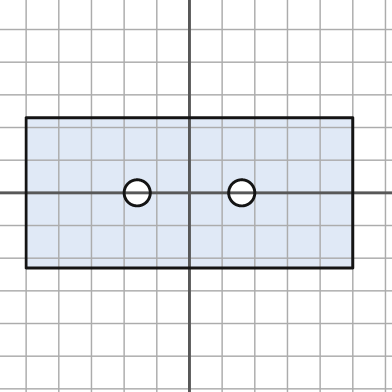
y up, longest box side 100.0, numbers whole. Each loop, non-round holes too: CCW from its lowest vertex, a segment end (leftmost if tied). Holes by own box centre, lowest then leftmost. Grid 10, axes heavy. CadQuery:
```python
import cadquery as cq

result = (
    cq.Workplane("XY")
    .moveTo(-50.0, -23.0)
    .lineTo(50.0, -23.0)
    .lineTo(50.0, 23.0)
    .lineTo(-50.0, 23.0)
    .close()
    .moveTo(-16.0, 0.0)
    .circle(4.0)
    .moveTo(16.0, 0.0)
    .circle(4.0)
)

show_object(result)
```